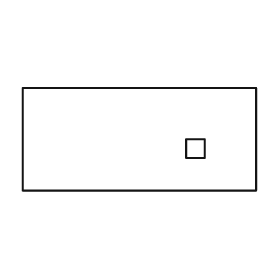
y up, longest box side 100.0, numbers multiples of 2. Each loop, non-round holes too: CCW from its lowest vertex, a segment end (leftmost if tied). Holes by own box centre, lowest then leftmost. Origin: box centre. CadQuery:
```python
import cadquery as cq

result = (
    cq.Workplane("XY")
    .moveTo(-50.0, -22.0)
    .lineTo(50.0, -22.0)
    .lineTo(50.0, 22.0)
    .lineTo(-50.0, 22.0)
    .close()
    .moveTo(20.0, -8.0)
    .lineTo(28.0, -8.0)
    .lineTo(28.0, 0.0)
    .lineTo(20.0, 0.0)
    .close()
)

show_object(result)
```